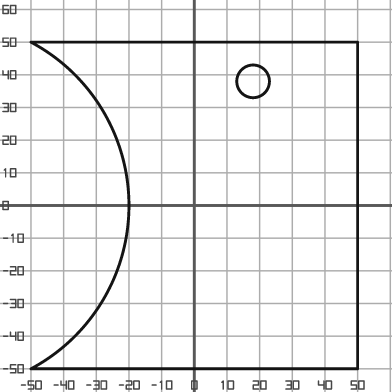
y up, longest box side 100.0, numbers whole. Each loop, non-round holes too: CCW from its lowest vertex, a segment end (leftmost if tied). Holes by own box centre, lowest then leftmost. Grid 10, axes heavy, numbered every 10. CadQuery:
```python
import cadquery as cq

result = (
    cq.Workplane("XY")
    .moveTo(-50.0, -50.0)
    .lineTo(50.0, -50.0)
    .lineTo(50.0, 50.0)
    .lineTo(-50.0, 50.0)
    .threePointArc((-20.0, 0.0), (-50.0, -50.0))
    .close()
    .moveTo(18.0, 38.0)
    .circle(5.0)
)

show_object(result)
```